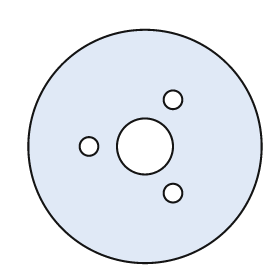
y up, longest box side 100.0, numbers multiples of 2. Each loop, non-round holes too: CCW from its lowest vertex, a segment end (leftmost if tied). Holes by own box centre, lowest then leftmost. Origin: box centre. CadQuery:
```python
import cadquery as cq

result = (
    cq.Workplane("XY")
    .moveTo(0.0, 0.0)
    .circle(50.0)
    .moveTo(12.0, -20.0)
    .circle(4.0)
    .moveTo(-24.0, 0.0)
    .circle(4.0)
    .moveTo(0.0, 0.0)
    .circle(12.0)
    .moveTo(12.0, 20.0)
    .circle(4.0)
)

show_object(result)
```